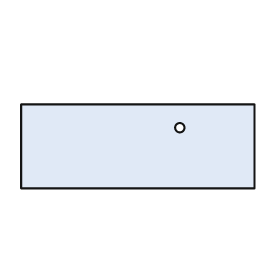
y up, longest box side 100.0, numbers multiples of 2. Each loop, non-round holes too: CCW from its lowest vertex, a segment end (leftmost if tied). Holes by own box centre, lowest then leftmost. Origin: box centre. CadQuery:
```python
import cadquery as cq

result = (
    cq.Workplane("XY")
    .moveTo(-50.0, -18.0)
    .lineTo(50.0, -18.0)
    .lineTo(50.0, 18.0)
    .lineTo(-50.0, 18.0)
    .close()
    .moveTo(18.0, 8.0)
    .circle(2.0)
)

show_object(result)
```